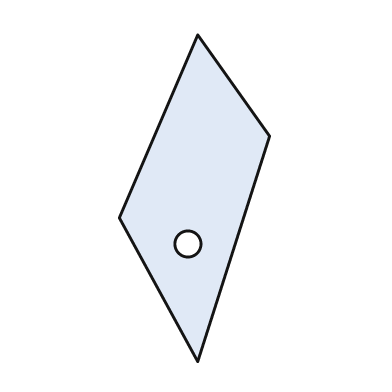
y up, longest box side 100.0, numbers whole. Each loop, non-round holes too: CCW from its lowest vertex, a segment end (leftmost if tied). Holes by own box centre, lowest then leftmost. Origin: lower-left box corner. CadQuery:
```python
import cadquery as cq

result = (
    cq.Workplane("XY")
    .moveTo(24.0, 0.0)
    .lineTo(46.0, 69.0)
    .lineTo(24.0, 100.0)
    .lineTo(0.0, 44.0)
    .close()
    .moveTo(21.0, 36.0)
    .circle(4.0)
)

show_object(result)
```